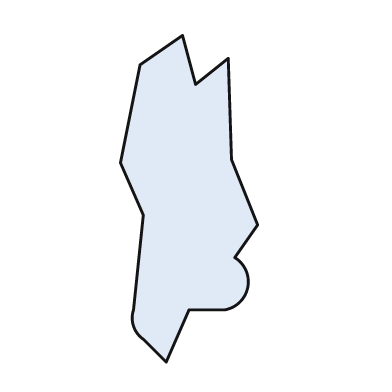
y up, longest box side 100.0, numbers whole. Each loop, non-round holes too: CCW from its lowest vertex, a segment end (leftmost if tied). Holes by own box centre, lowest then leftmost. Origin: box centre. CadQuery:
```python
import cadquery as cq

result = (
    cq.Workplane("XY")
    .moveTo(-7.0, -50.0)
    .lineTo(0.0, -34.0)
    .lineTo(11.0, -34.0)
    .threePointArc((18.0, -27.0), (14.0, -18.0))
    .lineTo(21.0, -8.0)
    .lineTo(13.0, 12.0)
    .lineTo(12.0, 43.0)
    .lineTo(2.0, 35.0)
    .lineTo(-2.0, 50.0)
    .lineTo(-15.0, 41.0)
    .lineTo(-21.0, 11.0)
    .lineTo(-14.0, -5.0)
    .lineTo(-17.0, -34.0)
    .threePointArc((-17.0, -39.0), (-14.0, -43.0))
    .close()
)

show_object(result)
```